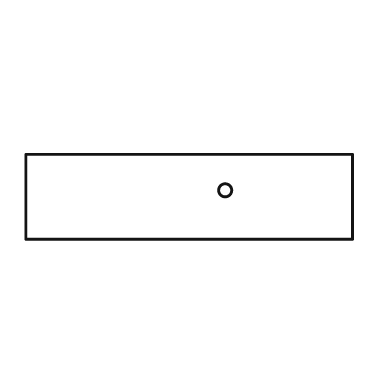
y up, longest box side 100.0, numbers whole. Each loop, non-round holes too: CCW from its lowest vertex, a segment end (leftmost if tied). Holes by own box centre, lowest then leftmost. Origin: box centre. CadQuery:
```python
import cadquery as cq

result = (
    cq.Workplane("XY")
    .moveTo(-50.0, -13.0)
    .lineTo(50.0, -13.0)
    .lineTo(50.0, 13.0)
    .lineTo(-50.0, 13.0)
    .close()
    .moveTo(11.0, 2.0)
    .circle(2.0)
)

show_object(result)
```